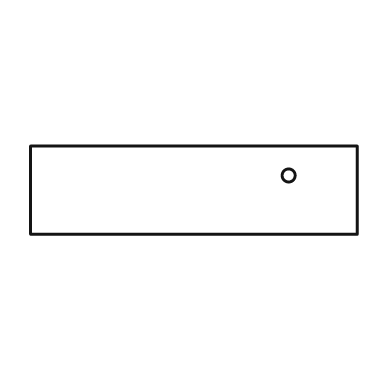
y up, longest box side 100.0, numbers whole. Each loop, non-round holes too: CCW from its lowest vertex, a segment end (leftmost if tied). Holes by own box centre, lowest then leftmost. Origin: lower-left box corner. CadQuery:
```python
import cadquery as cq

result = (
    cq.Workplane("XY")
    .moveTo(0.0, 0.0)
    .lineTo(100.0, 0.0)
    .lineTo(100.0, 27.0)
    .lineTo(0.0, 27.0)
    .close()
    .moveTo(79.0, 18.0)
    .circle(2.0)
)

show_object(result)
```